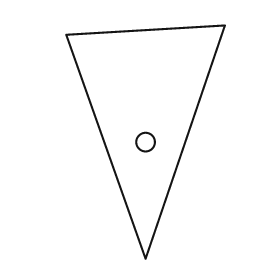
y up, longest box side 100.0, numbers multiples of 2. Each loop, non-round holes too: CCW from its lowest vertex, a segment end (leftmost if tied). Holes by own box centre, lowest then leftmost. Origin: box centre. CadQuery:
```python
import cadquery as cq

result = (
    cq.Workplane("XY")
    .moveTo(0.0, -50.0)
    .lineTo(34.0, 50.0)
    .lineTo(-34.0, 46.0)
    .close()
    .moveTo(0.0, 0.0)
    .circle(4.0)
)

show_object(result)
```